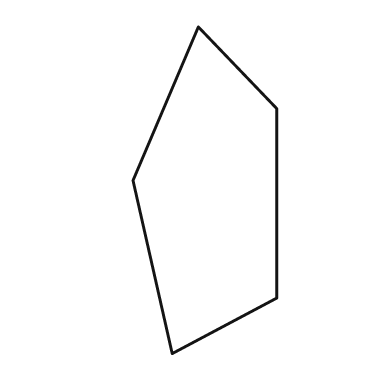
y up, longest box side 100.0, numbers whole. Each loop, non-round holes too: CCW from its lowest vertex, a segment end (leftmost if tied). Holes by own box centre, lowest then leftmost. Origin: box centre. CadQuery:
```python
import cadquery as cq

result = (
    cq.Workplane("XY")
    .moveTo(-10.0, -50.0)
    .lineTo(22.0, -33.0)
    .lineTo(22.0, 25.0)
    .lineTo(-2.0, 50.0)
    .lineTo(-22.0, 3.0)
    .close()
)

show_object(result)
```